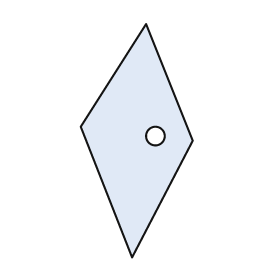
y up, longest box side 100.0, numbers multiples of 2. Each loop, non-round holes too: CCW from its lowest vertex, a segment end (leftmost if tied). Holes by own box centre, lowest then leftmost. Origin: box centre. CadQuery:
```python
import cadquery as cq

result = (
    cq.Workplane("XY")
    .moveTo(-2.0, -50.0)
    .lineTo(24.0, 0.0)
    .lineTo(4.0, 50.0)
    .lineTo(-24.0, 6.0)
    .close()
    .moveTo(8.0, 2.0)
    .circle(4.0)
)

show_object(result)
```